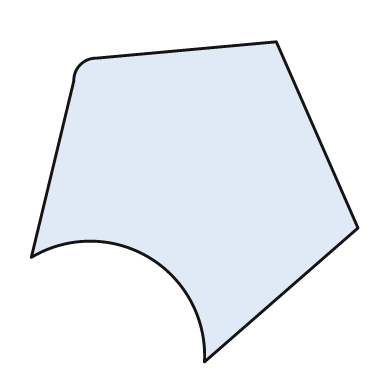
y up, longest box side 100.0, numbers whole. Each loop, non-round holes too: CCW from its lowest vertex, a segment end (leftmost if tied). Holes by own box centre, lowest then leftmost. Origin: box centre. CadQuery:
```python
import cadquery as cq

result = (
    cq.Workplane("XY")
    .moveTo(3.0, -49.0)
    .lineTo(50.0, -8.0)
    .lineTo(25.0, 49.0)
    .lineTo(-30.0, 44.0)
    .threePointArc((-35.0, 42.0), (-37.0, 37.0))
    .lineTo(-50.0, -17.0)
    .threePointArc((-14.0, -17.0), (3.0, -49.0))
    .close()
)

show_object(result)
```